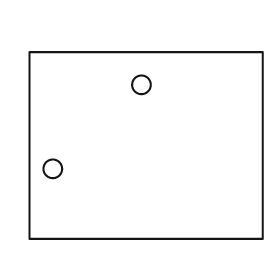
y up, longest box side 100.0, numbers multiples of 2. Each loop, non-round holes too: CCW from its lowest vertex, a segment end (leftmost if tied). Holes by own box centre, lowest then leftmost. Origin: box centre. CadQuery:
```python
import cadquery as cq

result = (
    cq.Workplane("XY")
    .moveTo(-50.0, -40.0)
    .lineTo(50.0, -40.0)
    .lineTo(50.0, 40.0)
    .lineTo(-50.0, 40.0)
    .close()
    .moveTo(-40.0, -10.0)
    .circle(4.0)
    .moveTo(-2.0, 26.0)
    .circle(4.0)
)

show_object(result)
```